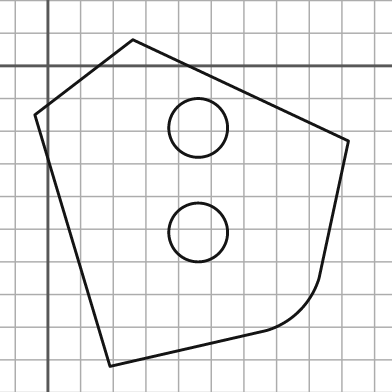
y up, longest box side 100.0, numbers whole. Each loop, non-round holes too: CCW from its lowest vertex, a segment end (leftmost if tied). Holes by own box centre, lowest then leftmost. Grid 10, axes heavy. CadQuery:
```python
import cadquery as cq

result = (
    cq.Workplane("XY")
    .moveTo(19.0, -92.0)
    .lineTo(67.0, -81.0)
    .threePointArc((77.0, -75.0), (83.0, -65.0))
    .lineTo(92.0, -23.0)
    .lineTo(26.0, 8.0)
    .lineTo(-4.0, -15.0)
    .close()
    .moveTo(46.0, -51.0)
    .circle(9.0)
    .moveTo(46.0, -19.0)
    .circle(9.0)
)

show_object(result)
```